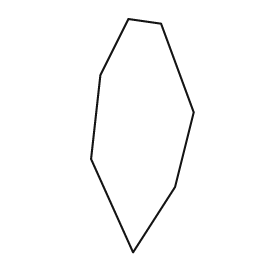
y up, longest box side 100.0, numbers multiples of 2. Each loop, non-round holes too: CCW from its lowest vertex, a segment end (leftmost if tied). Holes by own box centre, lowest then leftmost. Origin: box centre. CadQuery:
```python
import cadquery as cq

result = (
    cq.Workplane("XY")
    .moveTo(-4.0, -50.0)
    .lineTo(14.0, -22.0)
    .lineTo(22.0, 10.0)
    .lineTo(8.0, 48.0)
    .lineTo(-6.0, 50.0)
    .lineTo(-18.0, 26.0)
    .lineTo(-22.0, -10.0)
    .close()
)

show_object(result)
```